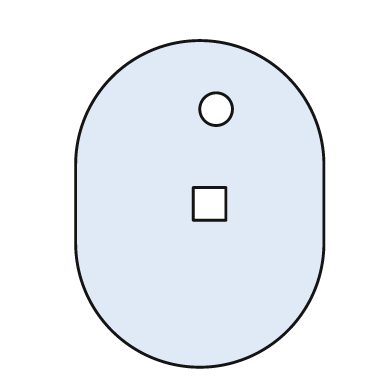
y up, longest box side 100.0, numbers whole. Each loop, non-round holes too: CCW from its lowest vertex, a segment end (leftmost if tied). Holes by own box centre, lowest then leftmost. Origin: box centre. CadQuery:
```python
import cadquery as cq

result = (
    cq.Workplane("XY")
    .moveTo(-38.0, -12.0)
    .threePointArc((0.0, -50.0), (38.0, -12.0))
    .lineTo(38.0, 12.0)
    .threePointArc((0.0, 50.0), (-38.0, 12.0))
    .close()
    .moveTo(-2.0, -5.0)
    .lineTo(8.0, -5.0)
    .lineTo(8.0, 5.0)
    .lineTo(-2.0, 5.0)
    .close()
    .moveTo(5.0, 29.0)
    .circle(5.0)
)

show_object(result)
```